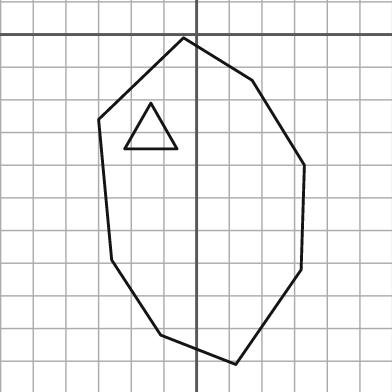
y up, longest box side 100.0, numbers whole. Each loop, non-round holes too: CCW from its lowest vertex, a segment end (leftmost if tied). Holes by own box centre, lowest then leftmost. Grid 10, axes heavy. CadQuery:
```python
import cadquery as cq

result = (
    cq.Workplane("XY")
    .moveTo(12.0, -101.0)
    .lineTo(32.0, -72.0)
    .lineTo(33.0, -40.0)
    .lineTo(17.0, -14.0)
    .lineTo(-4.0, -1.0)
    .lineTo(-30.0, -26.0)
    .lineTo(-26.0, -69.0)
    .lineTo(-11.0, -92.0)
    .close()
    .moveTo(-22.0, -35.0)
    .lineTo(-6.0, -35.0)
    .lineTo(-14.0, -21.0)
    .close()
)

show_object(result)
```